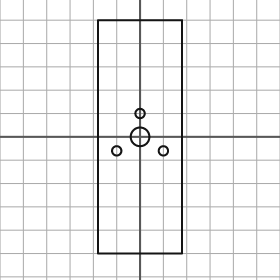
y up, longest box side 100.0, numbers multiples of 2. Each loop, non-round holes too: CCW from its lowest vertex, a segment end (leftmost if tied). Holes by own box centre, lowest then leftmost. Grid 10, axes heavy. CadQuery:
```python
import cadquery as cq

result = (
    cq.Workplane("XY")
    .moveTo(-18.0, -50.0)
    .lineTo(18.0, -50.0)
    .lineTo(18.0, 50.0)
    .lineTo(-18.0, 50.0)
    .close()
    .moveTo(-10.0, -6.0)
    .circle(2.0)
    .moveTo(10.0, -6.0)
    .circle(2.0)
    .moveTo(0.0, 0.0)
    .circle(4.0)
    .moveTo(0.0, 10.0)
    .circle(2.0)
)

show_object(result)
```